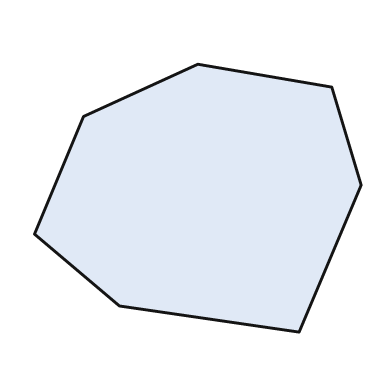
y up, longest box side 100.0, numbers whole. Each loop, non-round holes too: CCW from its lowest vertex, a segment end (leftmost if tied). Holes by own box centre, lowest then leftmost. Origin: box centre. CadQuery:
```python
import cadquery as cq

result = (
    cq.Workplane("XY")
    .moveTo(31.0, -41.0)
    .lineTo(50.0, 4.0)
    .lineTo(41.0, 34.0)
    .lineTo(0.0, 41.0)
    .lineTo(-35.0, 25.0)
    .lineTo(-50.0, -11.0)
    .lineTo(-24.0, -33.0)
    .close()
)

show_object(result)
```